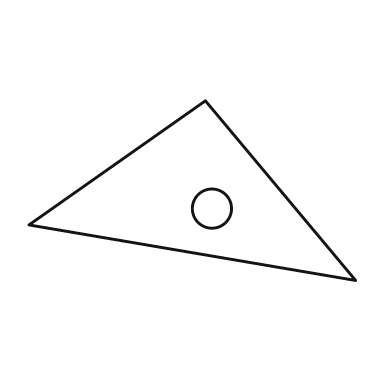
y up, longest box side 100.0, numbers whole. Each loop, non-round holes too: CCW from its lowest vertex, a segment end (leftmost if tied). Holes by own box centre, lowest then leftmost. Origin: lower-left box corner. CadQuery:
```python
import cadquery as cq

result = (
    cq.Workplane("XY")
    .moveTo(100.0, 0.0)
    .lineTo(54.0, 55.0)
    .lineTo(0.0, 17.0)
    .close()
    .moveTo(56.0, 22.0)
    .circle(6.0)
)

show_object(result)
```